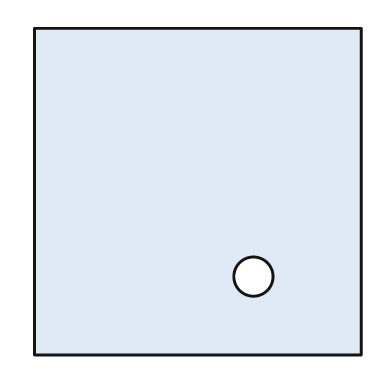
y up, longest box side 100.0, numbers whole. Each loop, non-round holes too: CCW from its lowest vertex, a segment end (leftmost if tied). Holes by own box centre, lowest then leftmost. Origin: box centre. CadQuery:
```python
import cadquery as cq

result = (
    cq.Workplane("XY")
    .moveTo(-50.0, -50.0)
    .lineTo(50.0, -50.0)
    .lineTo(50.0, 50.0)
    .lineTo(-50.0, 50.0)
    .close()
    .moveTo(17.0, -26.0)
    .circle(6.0)
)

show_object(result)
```